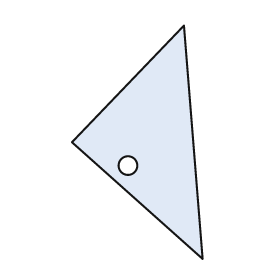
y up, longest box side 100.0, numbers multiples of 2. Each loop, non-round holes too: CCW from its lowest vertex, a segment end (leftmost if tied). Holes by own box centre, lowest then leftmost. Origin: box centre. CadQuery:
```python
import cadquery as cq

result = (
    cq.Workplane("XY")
    .moveTo(28.0, -50.0)
    .lineTo(20.0, 50.0)
    .lineTo(-28.0, 0.0)
    .close()
    .moveTo(-4.0, -10.0)
    .circle(4.0)
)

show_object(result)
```